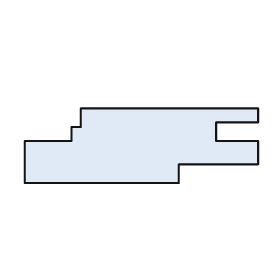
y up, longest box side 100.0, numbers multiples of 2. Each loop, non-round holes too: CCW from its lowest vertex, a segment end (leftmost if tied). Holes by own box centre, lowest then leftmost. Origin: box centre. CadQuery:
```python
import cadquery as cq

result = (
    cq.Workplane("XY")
    .moveTo(-50.0, -16.0)
    .lineTo(16.0, -16.0)
    .lineTo(16.0, -8.0)
    .lineTo(50.0, -8.0)
    .lineTo(50.0, 2.0)
    .lineTo(32.0, 2.0)
    .lineTo(32.0, 10.0)
    .lineTo(50.0, 10.0)
    .lineTo(50.0, 16.0)
    .lineTo(-26.0, 16.0)
    .lineTo(-26.0, 8.0)
    .lineTo(-30.0, 8.0)
    .lineTo(-30.0, 2.0)
    .lineTo(-50.0, 2.0)
    .close()
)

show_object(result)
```